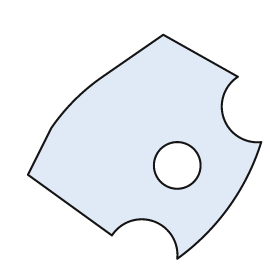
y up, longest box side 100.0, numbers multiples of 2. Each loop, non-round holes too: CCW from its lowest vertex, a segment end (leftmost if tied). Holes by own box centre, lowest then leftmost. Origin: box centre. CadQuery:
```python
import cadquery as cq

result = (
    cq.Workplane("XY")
    .moveTo(14.0, -48.0)
    .threePointArc((36.0, -26.0), (50.0, 2.0))
    .threePointArc((34.0, 12.0), (40.0, 30.0))
    .lineTo(8.0, 48.0)
    .lineTo(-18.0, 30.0)
    .threePointArc((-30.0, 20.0), (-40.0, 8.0))
    .lineTo(-50.0, -12.0)
    .lineTo(-14.0, -38.0)
    .threePointArc((4.0, -32.0), (14.0, -48.0))
    .close()
    .moveTo(14.0, -8.0)
    .circle(10.0)
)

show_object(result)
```